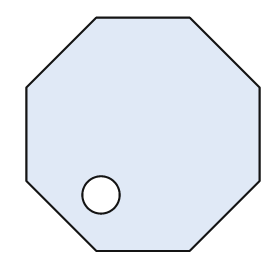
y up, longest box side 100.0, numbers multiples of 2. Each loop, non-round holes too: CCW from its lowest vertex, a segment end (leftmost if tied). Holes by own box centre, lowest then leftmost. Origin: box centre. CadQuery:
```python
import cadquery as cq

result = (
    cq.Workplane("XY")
    .moveTo(-20.0, -50.0)
    .lineTo(20.0, -50.0)
    .lineTo(50.0, -20.0)
    .lineTo(50.0, 20.0)
    .lineTo(20.0, 50.0)
    .lineTo(-20.0, 50.0)
    .lineTo(-50.0, 20.0)
    .lineTo(-50.0, -20.0)
    .close()
    .moveTo(-18.0, -26.0)
    .circle(8.0)
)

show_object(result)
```